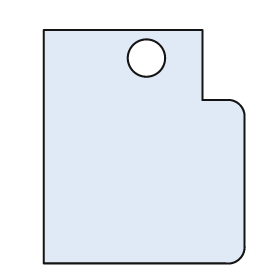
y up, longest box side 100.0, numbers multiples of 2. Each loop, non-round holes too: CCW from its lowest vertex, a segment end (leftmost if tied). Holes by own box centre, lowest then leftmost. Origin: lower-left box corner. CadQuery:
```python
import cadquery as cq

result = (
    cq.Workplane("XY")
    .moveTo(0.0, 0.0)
    .lineTo(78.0, 0.0)
    .threePointArc((84.0, 2.0), (86.0, 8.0))
    .lineTo(86.0, 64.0)
    .threePointArc((84.0, 68.0), (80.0, 70.0))
    .lineTo(68.0, 70.0)
    .lineTo(68.0, 100.0)
    .lineTo(0.0, 100.0)
    .close()
    .moveTo(44.0, 88.0)
    .circle(8.0)
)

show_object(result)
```